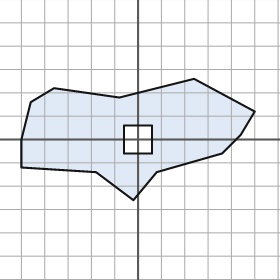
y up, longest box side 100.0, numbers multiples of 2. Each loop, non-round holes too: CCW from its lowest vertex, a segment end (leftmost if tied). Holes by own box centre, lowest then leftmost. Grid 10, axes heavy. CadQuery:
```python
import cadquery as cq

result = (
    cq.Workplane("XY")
    .moveTo(-2.0, -26.0)
    .lineTo(8.0, -14.0)
    .lineTo(36.0, -6.0)
    .lineTo(44.0, 2.0)
    .lineTo(50.0, 12.0)
    .lineTo(24.0, 26.0)
    .lineTo(-8.0, 18.0)
    .lineTo(-36.0, 22.0)
    .lineTo(-46.0, 16.0)
    .lineTo(-50.0, 0.0)
    .lineTo(-50.0, -12.0)
    .lineTo(-18.0, -14.0)
    .close()
    .moveTo(-6.0, -6.0)
    .lineTo(6.0, -6.0)
    .lineTo(6.0, 6.0)
    .lineTo(-6.0, 6.0)
    .close()
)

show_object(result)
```